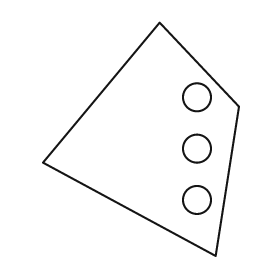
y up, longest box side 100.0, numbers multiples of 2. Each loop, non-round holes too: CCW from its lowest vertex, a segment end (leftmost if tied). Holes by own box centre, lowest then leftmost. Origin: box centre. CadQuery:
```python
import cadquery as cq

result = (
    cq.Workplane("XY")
    .moveTo(32.0, -50.0)
    .lineTo(42.0, 14.0)
    .lineTo(8.0, 50.0)
    .lineTo(-42.0, -10.0)
    .close()
    .moveTo(24.0, -26.0)
    .circle(6.0)
    .moveTo(24.0, -4.0)
    .circle(6.0)
    .moveTo(24.0, 18.0)
    .circle(6.0)
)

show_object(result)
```